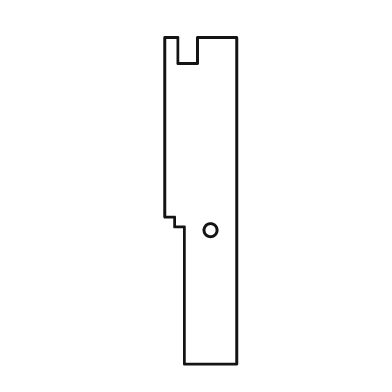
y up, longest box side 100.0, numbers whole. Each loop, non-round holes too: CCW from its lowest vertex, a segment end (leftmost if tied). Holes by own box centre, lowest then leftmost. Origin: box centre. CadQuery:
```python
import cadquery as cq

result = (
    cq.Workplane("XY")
    .moveTo(-5.0, -50.0)
    .lineTo(11.0, -50.0)
    .lineTo(11.0, 50.0)
    .lineTo(-1.0, 50.0)
    .lineTo(-1.0, 42.0)
    .lineTo(-7.0, 42.0)
    .lineTo(-7.0, 50.0)
    .lineTo(-11.0, 50.0)
    .lineTo(-11.0, -5.0)
    .lineTo(-8.0, -5.0)
    .lineTo(-8.0, -8.0)
    .lineTo(-5.0, -8.0)
    .close()
    .moveTo(3.0, -9.0)
    .circle(2.0)
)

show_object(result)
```